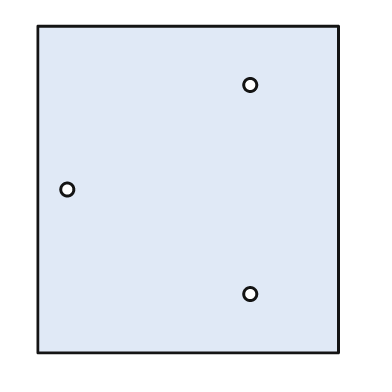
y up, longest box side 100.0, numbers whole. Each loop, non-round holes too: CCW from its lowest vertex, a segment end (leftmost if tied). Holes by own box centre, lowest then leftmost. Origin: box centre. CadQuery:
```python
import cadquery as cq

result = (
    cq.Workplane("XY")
    .moveTo(-46.0, -50.0)
    .lineTo(46.0, -50.0)
    .lineTo(46.0, 50.0)
    .lineTo(-46.0, 50.0)
    .close()
    .moveTo(19.0, -32.0)
    .circle(2.0)
    .moveTo(-37.0, 0.0)
    .circle(2.0)
    .moveTo(19.0, 32.0)
    .circle(2.0)
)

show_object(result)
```